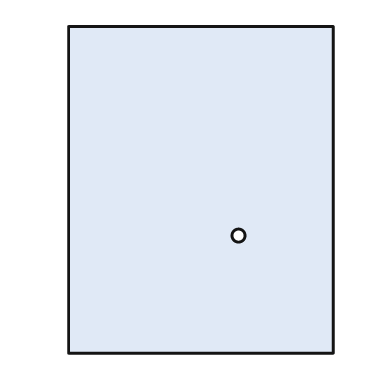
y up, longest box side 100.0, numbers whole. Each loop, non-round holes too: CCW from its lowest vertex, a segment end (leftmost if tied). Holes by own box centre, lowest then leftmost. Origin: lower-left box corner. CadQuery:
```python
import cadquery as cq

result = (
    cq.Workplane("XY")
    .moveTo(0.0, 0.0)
    .lineTo(81.0, 0.0)
    .lineTo(81.0, 100.0)
    .lineTo(0.0, 100.0)
    .close()
    .moveTo(52.0, 36.0)
    .circle(2.0)
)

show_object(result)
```